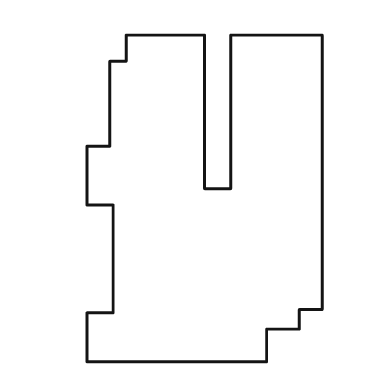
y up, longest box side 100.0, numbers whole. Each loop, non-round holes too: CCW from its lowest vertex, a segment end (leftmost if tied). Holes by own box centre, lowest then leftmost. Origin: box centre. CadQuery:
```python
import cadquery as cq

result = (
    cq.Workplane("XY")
    .moveTo(-36.0, -50.0)
    .lineTo(19.0, -50.0)
    .lineTo(19.0, -40.0)
    .lineTo(29.0, -40.0)
    .lineTo(29.0, -34.0)
    .lineTo(36.0, -34.0)
    .lineTo(36.0, 50.0)
    .lineTo(8.0, 50.0)
    .lineTo(8.0, 3.0)
    .lineTo(0.0, 3.0)
    .lineTo(0.0, 50.0)
    .lineTo(-24.0, 50.0)
    .lineTo(-24.0, 42.0)
    .lineTo(-29.0, 42.0)
    .lineTo(-29.0, 16.0)
    .lineTo(-36.0, 16.0)
    .lineTo(-36.0, -2.0)
    .lineTo(-28.0, -2.0)
    .lineTo(-28.0, -35.0)
    .lineTo(-36.0, -35.0)
    .close()
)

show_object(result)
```